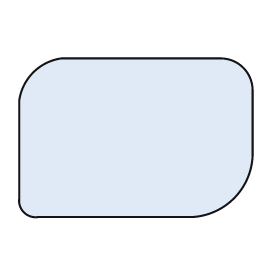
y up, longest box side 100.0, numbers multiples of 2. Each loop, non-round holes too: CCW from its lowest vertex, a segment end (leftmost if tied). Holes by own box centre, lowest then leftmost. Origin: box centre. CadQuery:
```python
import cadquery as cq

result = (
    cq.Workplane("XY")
    .moveTo(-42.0, -34.0)
    .lineTo(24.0, -34.0)
    .threePointArc((42.0, -26.0), (50.0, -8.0))
    .lineTo(50.0, 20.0)
    .threePointArc((46.0, 30.0), (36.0, 34.0))
    .lineTo(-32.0, 34.0)
    .threePointArc((-44.0, 28.0), (-50.0, 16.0))
    .lineTo(-50.0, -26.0)
    .threePointArc((-48.0, -32.0), (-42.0, -34.0))
    .close()
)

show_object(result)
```